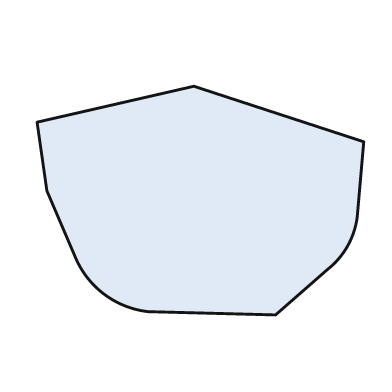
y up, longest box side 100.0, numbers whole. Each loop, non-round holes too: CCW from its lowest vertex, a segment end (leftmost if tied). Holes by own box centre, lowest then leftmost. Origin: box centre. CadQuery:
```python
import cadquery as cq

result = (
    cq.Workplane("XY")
    .moveTo(23.0, -35.0)
    .lineTo(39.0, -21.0)
    .threePointArc((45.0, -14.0), (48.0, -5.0))
    .lineTo(50.0, 18.0)
    .lineTo(-2.0, 35.0)
    .lineTo(-50.0, 24.0)
    .lineTo(-47.0, 3.0)
    .lineTo(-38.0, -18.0)
    .threePointArc((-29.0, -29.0), (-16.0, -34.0))
    .close()
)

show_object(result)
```